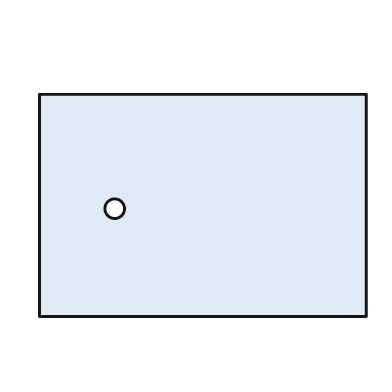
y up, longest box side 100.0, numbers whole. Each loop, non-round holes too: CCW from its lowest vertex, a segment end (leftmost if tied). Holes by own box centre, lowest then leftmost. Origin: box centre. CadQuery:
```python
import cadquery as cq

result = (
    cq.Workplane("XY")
    .moveTo(-50.0, -34.0)
    .lineTo(50.0, -34.0)
    .lineTo(50.0, 34.0)
    .lineTo(-50.0, 34.0)
    .close()
    .moveTo(-27.0, -1.0)
    .circle(3.0)
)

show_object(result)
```